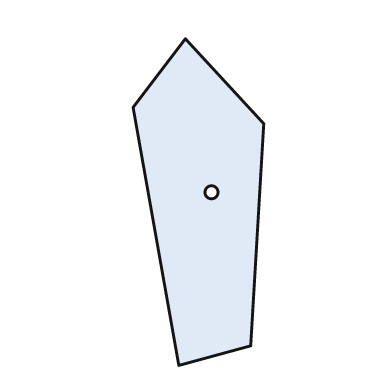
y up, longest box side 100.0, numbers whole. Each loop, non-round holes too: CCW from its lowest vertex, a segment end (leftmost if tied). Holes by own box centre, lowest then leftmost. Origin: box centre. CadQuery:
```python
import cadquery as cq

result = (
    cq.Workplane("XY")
    .moveTo(-6.0, -50.0)
    .lineTo(16.0, -44.0)
    .lineTo(20.0, 24.0)
    .lineTo(-4.0, 50.0)
    .lineTo(-20.0, 29.0)
    .close()
    .moveTo(4.0, 3.0)
    .circle(2.0)
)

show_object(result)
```